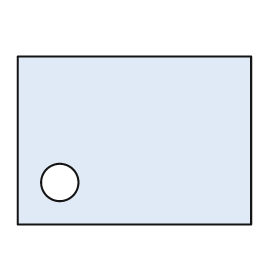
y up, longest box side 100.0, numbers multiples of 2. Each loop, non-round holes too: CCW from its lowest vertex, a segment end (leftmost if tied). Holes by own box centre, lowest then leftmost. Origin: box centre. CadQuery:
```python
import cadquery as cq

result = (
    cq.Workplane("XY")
    .moveTo(-50.0, -36.0)
    .lineTo(50.0, -36.0)
    .lineTo(50.0, 36.0)
    .lineTo(-50.0, 36.0)
    .close()
    .moveTo(-32.0, -18.0)
    .circle(8.0)
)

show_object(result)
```